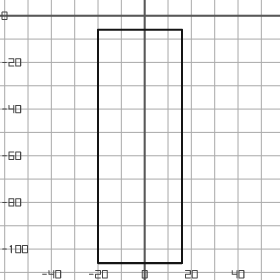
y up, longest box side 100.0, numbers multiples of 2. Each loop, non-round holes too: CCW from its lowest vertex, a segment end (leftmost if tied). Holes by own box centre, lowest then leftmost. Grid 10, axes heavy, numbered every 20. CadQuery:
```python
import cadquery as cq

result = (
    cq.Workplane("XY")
    .moveTo(-20.0, -106.0)
    .lineTo(16.0, -106.0)
    .lineTo(16.0, -6.0)
    .lineTo(-20.0, -6.0)
    .close()
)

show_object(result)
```